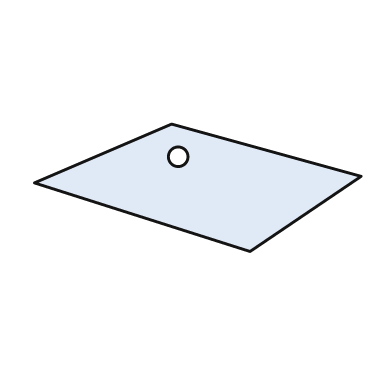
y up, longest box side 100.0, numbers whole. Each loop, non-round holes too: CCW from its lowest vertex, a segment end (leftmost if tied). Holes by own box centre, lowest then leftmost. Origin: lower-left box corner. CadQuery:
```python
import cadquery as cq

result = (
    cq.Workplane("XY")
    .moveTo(66.0, 0.0)
    .lineTo(100.0, 23.0)
    .lineTo(42.0, 39.0)
    .lineTo(0.0, 21.0)
    .close()
    .moveTo(44.0, 29.0)
    .circle(3.0)
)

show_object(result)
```